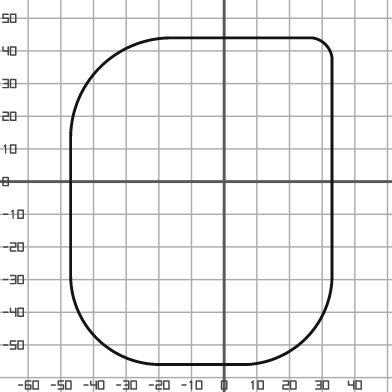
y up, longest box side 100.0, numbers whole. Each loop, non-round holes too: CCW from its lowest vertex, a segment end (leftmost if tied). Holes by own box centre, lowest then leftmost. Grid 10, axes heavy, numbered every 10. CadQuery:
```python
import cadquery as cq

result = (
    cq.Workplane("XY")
    .moveTo(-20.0, -56.0)
    .lineTo(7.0, -56.0)
    .threePointArc((25.0, -48.0), (33.0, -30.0))
    .lineTo(33.0, 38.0)
    .threePointArc((31.0, 42.0), (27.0, 44.0))
    .lineTo(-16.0, 44.0)
    .threePointArc((-38.0, 35.0), (-47.0, 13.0))
    .lineTo(-47.0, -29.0)
    .threePointArc((-39.0, -48.0), (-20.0, -56.0))
    .close()
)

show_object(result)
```